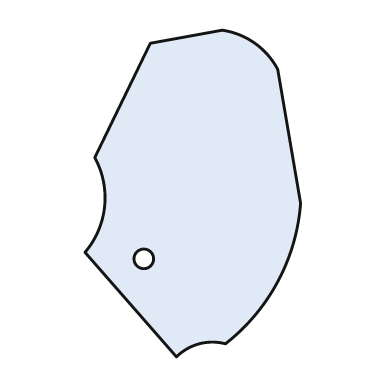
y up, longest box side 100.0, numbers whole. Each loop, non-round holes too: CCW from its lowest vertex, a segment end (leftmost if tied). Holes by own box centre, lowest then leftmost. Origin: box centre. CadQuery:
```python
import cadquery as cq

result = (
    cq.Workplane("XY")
    .moveTo(-5.0, -50.0)
    .threePointArc((2.0, -46.0), (10.0, -46.0))
    .threePointArc((26.0, -27.0), (33.0, -3.0))
    .lineTo(26.0, 38.0)
    .threePointArc((19.0, 46.0), (9.0, 50.0))
    .lineTo(-13.0, 46.0)
    .lineTo(-30.0, 11.0)
    .threePointArc((-27.0, -4.0), (-33.0, -18.0))
    .close()
    .moveTo(-15.0, -20.0)
    .circle(3.0)
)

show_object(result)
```